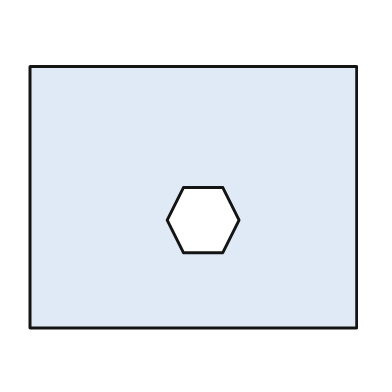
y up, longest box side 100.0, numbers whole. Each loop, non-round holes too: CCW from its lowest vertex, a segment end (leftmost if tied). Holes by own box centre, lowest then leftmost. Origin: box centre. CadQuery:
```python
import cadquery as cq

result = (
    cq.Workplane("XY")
    .moveTo(-50.0, -40.0)
    .lineTo(50.0, -40.0)
    .lineTo(50.0, 40.0)
    .lineTo(-50.0, 40.0)
    .close()
    .moveTo(-3.0, -17.0)
    .lineTo(9.0, -17.0)
    .lineTo(14.0, -7.0)
    .lineTo(9.0, 3.0)
    .lineTo(-3.0, 3.0)
    .lineTo(-8.0, -7.0)
    .close()
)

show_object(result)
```